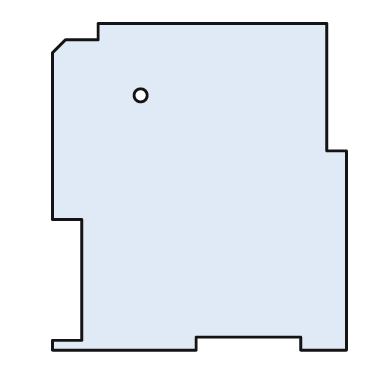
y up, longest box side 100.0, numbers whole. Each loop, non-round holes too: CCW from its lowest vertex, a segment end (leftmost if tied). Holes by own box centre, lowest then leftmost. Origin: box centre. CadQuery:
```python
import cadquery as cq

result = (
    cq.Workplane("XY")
    .moveTo(-45.0, -50.0)
    .lineTo(-1.0, -50.0)
    .lineTo(-1.0, -46.0)
    .lineTo(31.0, -46.0)
    .lineTo(31.0, -50.0)
    .lineTo(45.0, -50.0)
    .lineTo(45.0, 11.0)
    .lineTo(39.0, 11.0)
    .lineTo(39.0, 50.0)
    .lineTo(-31.0, 50.0)
    .lineTo(-31.0, 45.0)
    .lineTo(-41.0, 45.0)
    .lineTo(-45.0, 41.0)
    .lineTo(-45.0, -10.0)
    .lineTo(-36.0, -10.0)
    .lineTo(-36.0, -47.0)
    .lineTo(-45.0, -47.0)
    .close()
    .moveTo(-18.0, 28.0)
    .circle(2.0)
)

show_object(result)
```